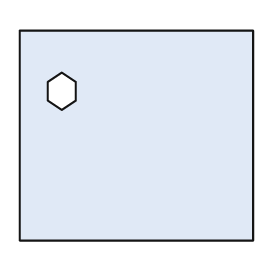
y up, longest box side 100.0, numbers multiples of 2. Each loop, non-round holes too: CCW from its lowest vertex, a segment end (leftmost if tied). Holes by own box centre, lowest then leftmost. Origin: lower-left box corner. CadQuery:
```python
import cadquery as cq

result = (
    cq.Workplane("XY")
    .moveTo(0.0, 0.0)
    .lineTo(100.0, 0.0)
    .lineTo(100.0, 90.0)
    .lineTo(0.0, 90.0)
    .close()
    .moveTo(18.0, 56.0)
    .lineTo(24.0, 60.0)
    .lineTo(24.0, 68.0)
    .lineTo(18.0, 72.0)
    .lineTo(12.0, 68.0)
    .lineTo(12.0, 60.0)
    .close()
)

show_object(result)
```